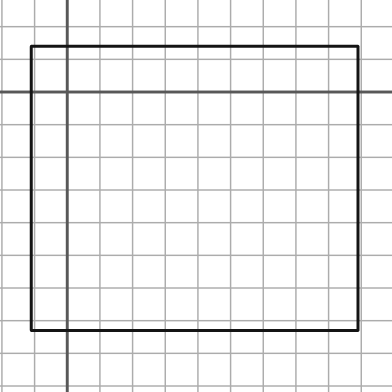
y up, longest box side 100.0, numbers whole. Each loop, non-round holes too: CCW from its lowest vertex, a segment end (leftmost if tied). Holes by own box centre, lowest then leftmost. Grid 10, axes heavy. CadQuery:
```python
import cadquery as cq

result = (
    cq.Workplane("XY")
    .moveTo(-11.0, -73.0)
    .lineTo(89.0, -73.0)
    .lineTo(89.0, 14.0)
    .lineTo(-11.0, 14.0)
    .close()
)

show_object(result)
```